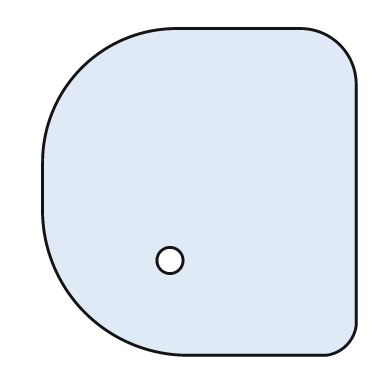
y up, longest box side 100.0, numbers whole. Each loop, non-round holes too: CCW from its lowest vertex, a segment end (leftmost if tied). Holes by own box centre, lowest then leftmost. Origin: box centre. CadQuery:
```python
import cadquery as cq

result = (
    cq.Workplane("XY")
    .moveTo(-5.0, -50.0)
    .lineTo(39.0, -50.0)
    .threePointArc((45.0, -47.0), (48.0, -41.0))
    .lineTo(48.0, 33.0)
    .threePointArc((43.0, 45.0), (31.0, 50.0))
    .lineTo(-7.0, 50.0)
    .threePointArc((-36.0, 38.0), (-48.0, 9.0))
    .lineTo(-48.0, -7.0)
    .threePointArc((-35.0, -37.0), (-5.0, -50.0))
    .close()
    .moveTo(-9.0, -21.0)
    .circle(4.0)
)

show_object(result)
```